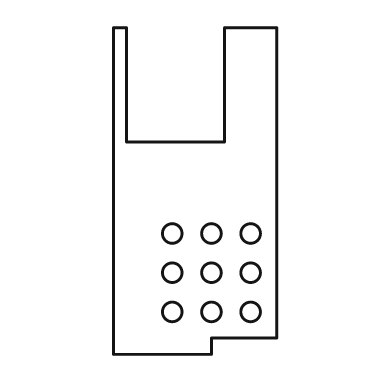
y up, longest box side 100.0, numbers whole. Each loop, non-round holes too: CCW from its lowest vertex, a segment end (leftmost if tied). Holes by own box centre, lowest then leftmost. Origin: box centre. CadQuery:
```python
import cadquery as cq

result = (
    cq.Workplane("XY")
    .moveTo(-25.0, -50.0)
    .lineTo(5.0, -50.0)
    .lineTo(5.0, -45.0)
    .lineTo(25.0, -45.0)
    .lineTo(25.0, 50.0)
    .lineTo(9.0, 50.0)
    .lineTo(9.0, 15.0)
    .lineTo(-21.0, 15.0)
    .lineTo(-21.0, 50.0)
    .lineTo(-25.0, 50.0)
    .close()
    .moveTo(-7.0, -37.0)
    .circle(3.0)
    .moveTo(5.0, -37.0)
    .circle(3.0)
    .moveTo(17.0, -37.0)
    .circle(3.0)
    .moveTo(-7.0, -25.0)
    .circle(3.0)
    .moveTo(5.0, -25.0)
    .circle(3.0)
    .moveTo(17.0, -25.0)
    .circle(3.0)
    .moveTo(-7.0, -13.0)
    .circle(3.0)
    .moveTo(5.0, -13.0)
    .circle(3.0)
    .moveTo(17.0, -13.0)
    .circle(3.0)
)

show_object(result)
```